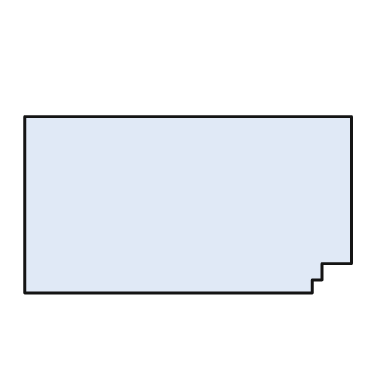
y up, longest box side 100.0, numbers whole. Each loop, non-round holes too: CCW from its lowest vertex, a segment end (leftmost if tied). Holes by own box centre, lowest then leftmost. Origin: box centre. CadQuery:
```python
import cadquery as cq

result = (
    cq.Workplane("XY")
    .moveTo(-50.0, -27.0)
    .lineTo(38.0, -27.0)
    .lineTo(38.0, -23.0)
    .lineTo(41.0, -23.0)
    .lineTo(41.0, -18.0)
    .lineTo(50.0, -18.0)
    .lineTo(50.0, 27.0)
    .lineTo(-50.0, 27.0)
    .close()
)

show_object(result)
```